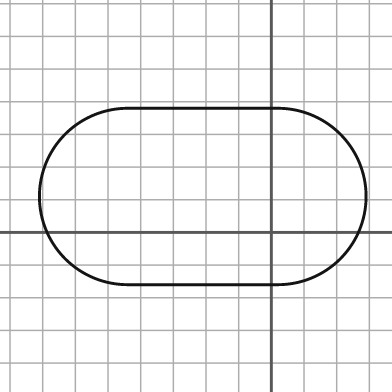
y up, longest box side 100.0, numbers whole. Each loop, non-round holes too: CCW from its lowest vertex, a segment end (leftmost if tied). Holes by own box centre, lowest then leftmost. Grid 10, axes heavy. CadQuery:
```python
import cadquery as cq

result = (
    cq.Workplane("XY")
    .moveTo(-44.0, -16.0)
    .lineTo(2.0, -16.0)
    .threePointArc((29.0, 11.0), (2.0, 38.0))
    .lineTo(-44.0, 38.0)
    .threePointArc((-71.0, 11.0), (-44.0, -16.0))
    .close()
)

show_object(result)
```